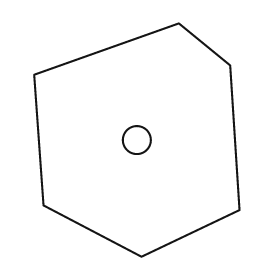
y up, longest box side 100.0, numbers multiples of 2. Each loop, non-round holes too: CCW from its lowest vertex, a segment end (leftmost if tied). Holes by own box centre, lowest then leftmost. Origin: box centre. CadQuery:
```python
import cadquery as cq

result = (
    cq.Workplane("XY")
    .moveTo(2.0, -50.0)
    .lineTo(44.0, -30.0)
    .lineTo(40.0, 32.0)
    .lineTo(18.0, 50.0)
    .lineTo(-44.0, 28.0)
    .lineTo(-40.0, -28.0)
    .close()
    .moveTo(0.0, 0.0)
    .circle(6.0)
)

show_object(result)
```